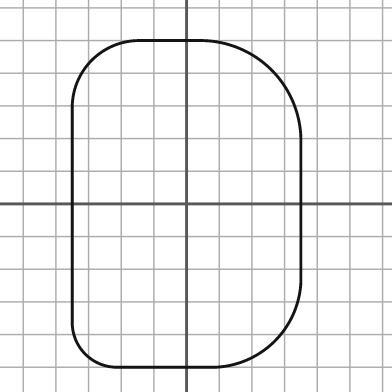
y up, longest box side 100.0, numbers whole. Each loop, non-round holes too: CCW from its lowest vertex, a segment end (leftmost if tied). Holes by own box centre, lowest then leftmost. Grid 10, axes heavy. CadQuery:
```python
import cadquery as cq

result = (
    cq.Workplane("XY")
    .moveTo(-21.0, -50.0)
    .lineTo(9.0, -50.0)
    .threePointArc((27.0, -42.0), (35.0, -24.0))
    .lineTo(35.0, 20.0)
    .threePointArc((26.0, 41.0), (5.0, 50.0))
    .lineTo(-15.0, 50.0)
    .threePointArc((-29.0, 44.0), (-35.0, 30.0))
    .lineTo(-35.0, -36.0)
    .threePointArc((-31.0, -46.0), (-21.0, -50.0))
    .close()
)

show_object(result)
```